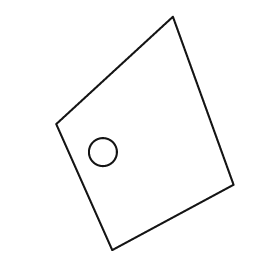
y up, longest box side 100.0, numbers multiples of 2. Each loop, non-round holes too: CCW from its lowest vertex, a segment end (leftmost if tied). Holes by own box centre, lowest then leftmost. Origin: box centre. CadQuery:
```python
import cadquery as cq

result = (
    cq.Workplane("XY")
    .moveTo(-14.0, -50.0)
    .lineTo(38.0, -22.0)
    .lineTo(12.0, 50.0)
    .lineTo(-38.0, 4.0)
    .close()
    .moveTo(-18.0, -8.0)
    .circle(6.0)
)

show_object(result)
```